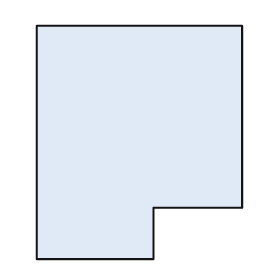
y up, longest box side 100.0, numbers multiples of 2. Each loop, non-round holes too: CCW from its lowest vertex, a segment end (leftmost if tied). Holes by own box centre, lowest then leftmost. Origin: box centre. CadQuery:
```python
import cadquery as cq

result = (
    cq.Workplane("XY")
    .moveTo(-44.0, -50.0)
    .lineTo(6.0, -50.0)
    .lineTo(6.0, -28.0)
    .lineTo(44.0, -28.0)
    .lineTo(44.0, 50.0)
    .lineTo(-44.0, 50.0)
    .close()
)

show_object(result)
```